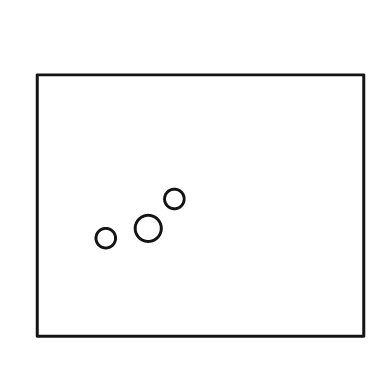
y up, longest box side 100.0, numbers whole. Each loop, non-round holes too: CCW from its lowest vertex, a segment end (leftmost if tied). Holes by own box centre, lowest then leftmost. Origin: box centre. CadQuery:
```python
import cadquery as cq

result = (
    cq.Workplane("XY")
    .moveTo(-50.0, -40.0)
    .lineTo(50.0, -40.0)
    .lineTo(50.0, 40.0)
    .lineTo(-50.0, 40.0)
    .close()
    .moveTo(-29.0, -10.0)
    .circle(3.0)
    .moveTo(-16.0, -7.0)
    .circle(4.0)
    .moveTo(-8.0, 2.0)
    .circle(3.0)
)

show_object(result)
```